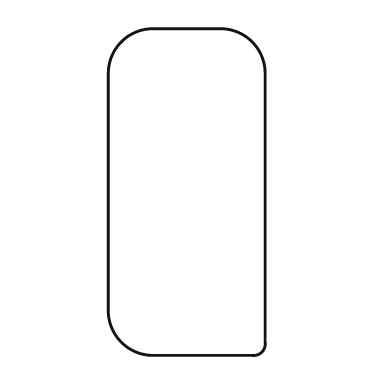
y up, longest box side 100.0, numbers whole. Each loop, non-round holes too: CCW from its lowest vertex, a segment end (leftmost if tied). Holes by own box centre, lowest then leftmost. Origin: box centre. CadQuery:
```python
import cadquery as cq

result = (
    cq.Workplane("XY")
    .moveTo(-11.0, -50.0)
    .lineTo(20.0, -50.0)
    .threePointArc((23.0, -49.0), (24.0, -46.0))
    .lineTo(24.0, 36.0)
    .threePointArc((20.0, 46.0), (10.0, 50.0))
    .lineTo(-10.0, 50.0)
    .threePointArc((-20.0, 46.0), (-24.0, 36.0))
    .lineTo(-24.0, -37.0)
    .threePointArc((-20.0, -46.0), (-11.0, -50.0))
    .close()
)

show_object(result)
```